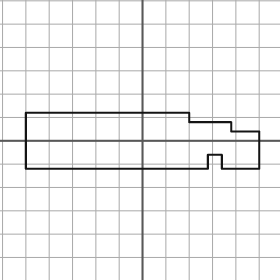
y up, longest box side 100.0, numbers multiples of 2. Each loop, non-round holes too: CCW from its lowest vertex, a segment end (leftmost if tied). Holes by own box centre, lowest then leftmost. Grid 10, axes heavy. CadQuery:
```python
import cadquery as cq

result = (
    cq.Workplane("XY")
    .moveTo(-50.0, -12.0)
    .lineTo(28.0, -12.0)
    .lineTo(28.0, -6.0)
    .lineTo(34.0, -6.0)
    .lineTo(34.0, -12.0)
    .lineTo(50.0, -12.0)
    .lineTo(50.0, 4.0)
    .lineTo(38.0, 4.0)
    .lineTo(38.0, 8.0)
    .lineTo(20.0, 8.0)
    .lineTo(20.0, 12.0)
    .lineTo(-50.0, 12.0)
    .close()
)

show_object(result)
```